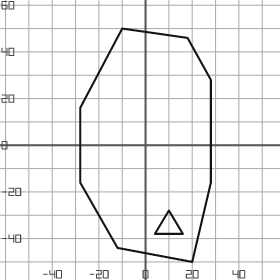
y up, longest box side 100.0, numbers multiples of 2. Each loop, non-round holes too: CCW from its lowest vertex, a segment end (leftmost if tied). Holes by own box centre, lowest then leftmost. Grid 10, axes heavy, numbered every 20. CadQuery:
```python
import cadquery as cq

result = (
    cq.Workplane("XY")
    .moveTo(20.0, -50.0)
    .lineTo(28.0, -16.0)
    .lineTo(28.0, 28.0)
    .lineTo(18.0, 46.0)
    .lineTo(-10.0, 50.0)
    .lineTo(-28.0, 16.0)
    .lineTo(-28.0, -16.0)
    .lineTo(-12.0, -44.0)
    .close()
    .moveTo(4.0, -38.0)
    .lineTo(16.0, -38.0)
    .lineTo(10.0, -28.0)
    .close()
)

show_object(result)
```